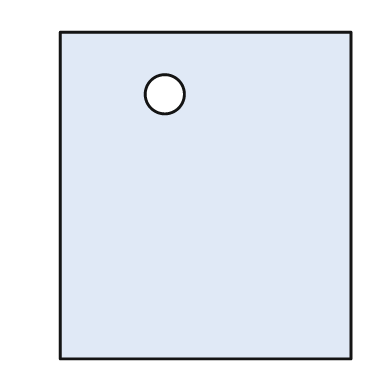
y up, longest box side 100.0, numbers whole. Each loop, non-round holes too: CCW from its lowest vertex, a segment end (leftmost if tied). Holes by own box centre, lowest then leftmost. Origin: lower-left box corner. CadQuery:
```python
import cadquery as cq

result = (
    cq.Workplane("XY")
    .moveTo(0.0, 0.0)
    .lineTo(89.0, 0.0)
    .lineTo(89.0, 100.0)
    .lineTo(0.0, 100.0)
    .close()
    .moveTo(32.0, 81.0)
    .circle(6.0)
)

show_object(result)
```